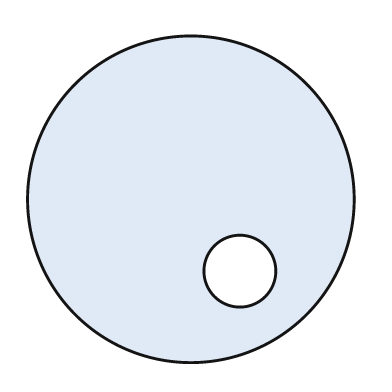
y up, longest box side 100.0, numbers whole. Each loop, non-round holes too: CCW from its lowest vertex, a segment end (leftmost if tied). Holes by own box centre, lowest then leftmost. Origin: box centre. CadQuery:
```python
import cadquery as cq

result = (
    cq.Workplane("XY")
    .moveTo(0.0, 0.0)
    .circle(50.0)
    .moveTo(15.0, -22.0)
    .circle(11.0)
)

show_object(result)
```